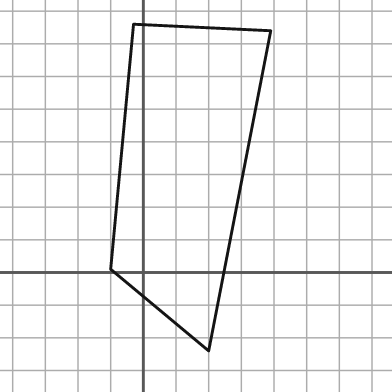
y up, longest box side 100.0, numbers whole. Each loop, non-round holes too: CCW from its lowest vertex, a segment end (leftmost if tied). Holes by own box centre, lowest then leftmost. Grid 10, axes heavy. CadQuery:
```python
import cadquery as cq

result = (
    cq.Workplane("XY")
    .moveTo(20.0, -24.0)
    .lineTo(39.0, 74.0)
    .lineTo(-3.0, 76.0)
    .lineTo(-10.0, 1.0)
    .close()
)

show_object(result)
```